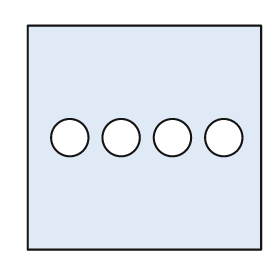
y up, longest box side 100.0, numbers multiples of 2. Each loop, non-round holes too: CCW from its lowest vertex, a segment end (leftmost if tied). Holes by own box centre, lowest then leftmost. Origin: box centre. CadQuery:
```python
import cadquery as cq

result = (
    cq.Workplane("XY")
    .moveTo(-50.0, -48.0)
    .lineTo(50.0, -48.0)
    .lineTo(50.0, 48.0)
    .lineTo(-50.0, 48.0)
    .close()
    .moveTo(-32.0, 0.0)
    .circle(8.0)
    .moveTo(-10.0, 0.0)
    .circle(8.0)
    .moveTo(12.0, 0.0)
    .circle(8.0)
    .moveTo(34.0, 0.0)
    .circle(8.0)
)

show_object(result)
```